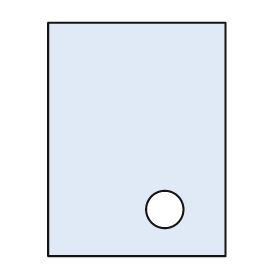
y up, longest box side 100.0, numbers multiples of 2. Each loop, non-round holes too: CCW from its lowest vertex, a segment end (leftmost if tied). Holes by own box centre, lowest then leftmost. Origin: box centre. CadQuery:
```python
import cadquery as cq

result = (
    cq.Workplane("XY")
    .moveTo(-38.0, -50.0)
    .lineTo(38.0, -50.0)
    .lineTo(38.0, 50.0)
    .lineTo(-38.0, 50.0)
    .close()
    .moveTo(12.0, -30.0)
    .circle(8.0)
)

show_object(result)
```